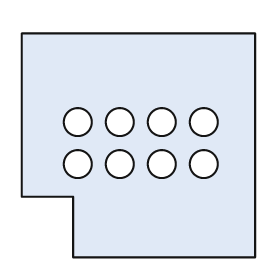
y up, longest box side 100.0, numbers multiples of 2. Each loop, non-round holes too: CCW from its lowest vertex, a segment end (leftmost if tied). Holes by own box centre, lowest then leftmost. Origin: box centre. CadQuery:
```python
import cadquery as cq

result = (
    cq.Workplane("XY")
    .moveTo(-28.0, -48.0)
    .lineTo(50.0, -48.0)
    .lineTo(50.0, 48.0)
    .lineTo(-50.0, 48.0)
    .lineTo(-50.0, -22.0)
    .lineTo(-28.0, -22.0)
    .close()
    .moveTo(-26.0, -8.0)
    .circle(6.0)
    .moveTo(-8.0, -8.0)
    .circle(6.0)
    .moveTo(10.0, -8.0)
    .circle(6.0)
    .moveTo(28.0, -8.0)
    .circle(6.0)
    .moveTo(-26.0, 10.0)
    .circle(6.0)
    .moveTo(-8.0, 10.0)
    .circle(6.0)
    .moveTo(10.0, 10.0)
    .circle(6.0)
    .moveTo(28.0, 10.0)
    .circle(6.0)
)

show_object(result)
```